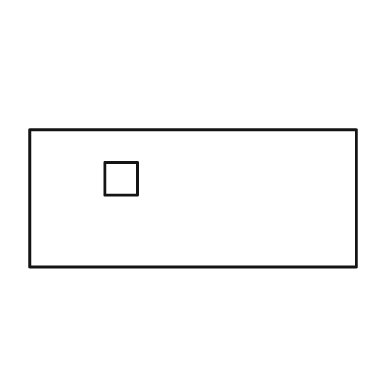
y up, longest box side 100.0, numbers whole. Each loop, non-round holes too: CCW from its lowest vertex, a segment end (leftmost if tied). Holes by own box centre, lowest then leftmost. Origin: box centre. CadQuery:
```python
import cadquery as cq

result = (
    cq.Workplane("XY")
    .moveTo(-50.0, -21.0)
    .lineTo(50.0, -21.0)
    .lineTo(50.0, 21.0)
    .lineTo(-50.0, 21.0)
    .close()
    .moveTo(-27.0, 1.0)
    .lineTo(-17.0, 1.0)
    .lineTo(-17.0, 11.0)
    .lineTo(-27.0, 11.0)
    .close()
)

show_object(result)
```